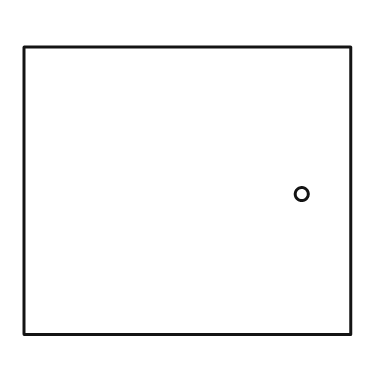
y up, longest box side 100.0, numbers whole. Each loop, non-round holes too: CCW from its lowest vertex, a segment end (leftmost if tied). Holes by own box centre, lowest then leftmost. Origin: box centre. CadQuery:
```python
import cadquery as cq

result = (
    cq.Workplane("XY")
    .moveTo(-50.0, -44.0)
    .lineTo(50.0, -44.0)
    .lineTo(50.0, 44.0)
    .lineTo(-50.0, 44.0)
    .close()
    .moveTo(35.0, -1.0)
    .circle(2.0)
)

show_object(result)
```